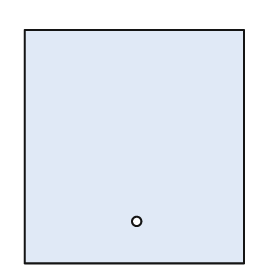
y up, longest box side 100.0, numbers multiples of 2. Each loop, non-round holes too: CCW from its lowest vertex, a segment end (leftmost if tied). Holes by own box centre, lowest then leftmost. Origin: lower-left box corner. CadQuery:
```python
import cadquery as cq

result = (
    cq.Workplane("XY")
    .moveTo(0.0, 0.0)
    .lineTo(94.0, 0.0)
    .lineTo(94.0, 100.0)
    .lineTo(0.0, 100.0)
    .close()
    .moveTo(48.0, 18.0)
    .circle(2.0)
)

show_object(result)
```